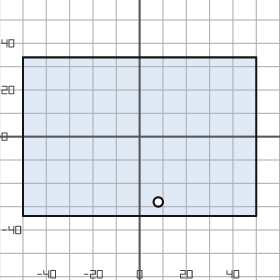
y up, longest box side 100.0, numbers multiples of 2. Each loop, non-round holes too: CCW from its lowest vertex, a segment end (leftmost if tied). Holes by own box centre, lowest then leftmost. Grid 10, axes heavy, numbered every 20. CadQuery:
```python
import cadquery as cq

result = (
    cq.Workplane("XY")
    .moveTo(-50.0, -34.0)
    .lineTo(50.0, -34.0)
    .lineTo(50.0, 34.0)
    .lineTo(-50.0, 34.0)
    .close()
    .moveTo(8.0, -28.0)
    .circle(2.0)
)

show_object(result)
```